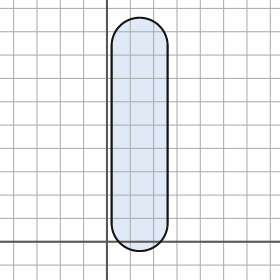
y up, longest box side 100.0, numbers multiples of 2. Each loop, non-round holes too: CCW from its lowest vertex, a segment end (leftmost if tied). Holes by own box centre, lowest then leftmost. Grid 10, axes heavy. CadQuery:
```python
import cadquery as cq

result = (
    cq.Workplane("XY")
    .moveTo(2.0, 8.0)
    .threePointArc((14.0, -4.0), (26.0, 8.0))
    .lineTo(26.0, 84.0)
    .threePointArc((14.0, 96.0), (2.0, 84.0))
    .close()
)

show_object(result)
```